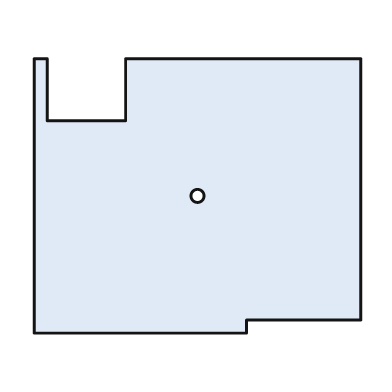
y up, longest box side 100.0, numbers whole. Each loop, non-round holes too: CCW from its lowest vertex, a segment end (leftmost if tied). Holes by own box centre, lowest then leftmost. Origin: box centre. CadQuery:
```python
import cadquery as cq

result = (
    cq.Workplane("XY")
    .moveTo(-50.0, -42.0)
    .lineTo(15.0, -42.0)
    .lineTo(15.0, -38.0)
    .lineTo(50.0, -38.0)
    .lineTo(50.0, 42.0)
    .lineTo(-22.0, 42.0)
    .lineTo(-22.0, 23.0)
    .lineTo(-46.0, 23.0)
    .lineTo(-46.0, 42.0)
    .lineTo(-50.0, 42.0)
    .close()
    .moveTo(0.0, 0.0)
    .circle(2.0)
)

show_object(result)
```